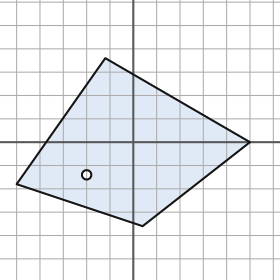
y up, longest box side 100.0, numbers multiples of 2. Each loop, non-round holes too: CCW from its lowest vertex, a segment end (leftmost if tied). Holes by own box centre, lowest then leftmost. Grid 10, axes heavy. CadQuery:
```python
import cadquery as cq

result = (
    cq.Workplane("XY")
    .moveTo(4.0, -36.0)
    .lineTo(50.0, 0.0)
    .lineTo(-12.0, 36.0)
    .lineTo(-50.0, -18.0)
    .close()
    .moveTo(-20.0, -14.0)
    .circle(2.0)
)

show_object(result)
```